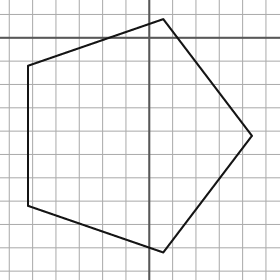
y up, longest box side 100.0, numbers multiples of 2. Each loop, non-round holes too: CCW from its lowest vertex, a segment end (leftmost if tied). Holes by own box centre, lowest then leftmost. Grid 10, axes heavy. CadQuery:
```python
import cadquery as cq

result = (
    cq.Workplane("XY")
    .moveTo(6.0, -92.0)
    .lineTo(44.0, -42.0)
    .lineTo(6.0, 8.0)
    .lineTo(-52.0, -12.0)
    .lineTo(-52.0, -72.0)
    .close()
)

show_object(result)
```